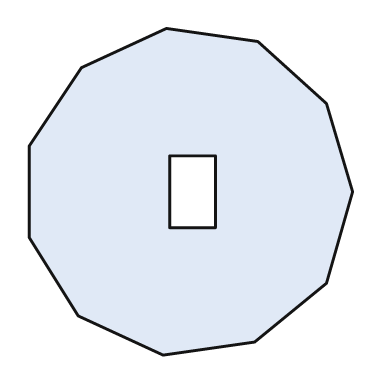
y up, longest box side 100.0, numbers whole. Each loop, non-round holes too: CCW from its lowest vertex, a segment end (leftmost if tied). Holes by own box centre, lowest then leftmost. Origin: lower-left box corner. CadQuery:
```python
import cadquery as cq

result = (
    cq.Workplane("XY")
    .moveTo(41.0, 0.0)
    .lineTo(69.0, 4.0)
    .lineTo(91.0, 22.0)
    .lineTo(99.0, 50.0)
    .lineTo(91.0, 77.0)
    .lineTo(70.0, 96.0)
    .lineTo(42.0, 100.0)
    .lineTo(16.0, 88.0)
    .lineTo(0.0, 64.0)
    .lineTo(0.0, 36.0)
    .lineTo(15.0, 12.0)
    .close()
    .moveTo(43.0, 39.0)
    .lineTo(57.0, 39.0)
    .lineTo(57.0, 61.0)
    .lineTo(43.0, 61.0)
    .close()
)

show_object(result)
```